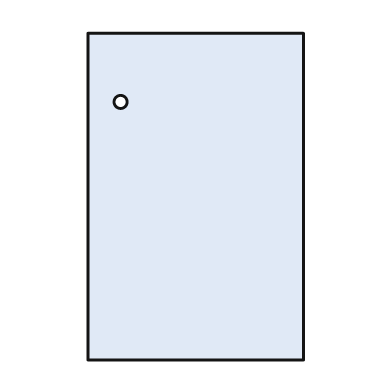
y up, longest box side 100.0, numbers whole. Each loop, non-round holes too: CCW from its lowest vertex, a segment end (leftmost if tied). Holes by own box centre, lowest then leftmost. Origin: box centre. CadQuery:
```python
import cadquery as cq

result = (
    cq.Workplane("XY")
    .moveTo(-33.0, -50.0)
    .lineTo(33.0, -50.0)
    .lineTo(33.0, 50.0)
    .lineTo(-33.0, 50.0)
    .close()
    .moveTo(-23.0, 29.0)
    .circle(2.0)
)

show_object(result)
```